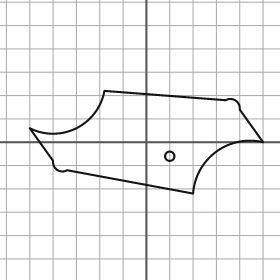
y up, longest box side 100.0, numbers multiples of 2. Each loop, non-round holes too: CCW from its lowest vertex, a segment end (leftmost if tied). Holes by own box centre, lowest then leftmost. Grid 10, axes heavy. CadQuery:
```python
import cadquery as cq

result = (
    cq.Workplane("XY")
    .moveTo(20.0, -22.0)
    .threePointArc((30.0, -4.0), (50.0, 0.0))
    .lineTo(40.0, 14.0)
    .threePointArc((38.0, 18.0), (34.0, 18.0))
    .lineTo(-18.0, 22.0)
    .threePointArc((-30.0, 6.0), (-50.0, 6.0))
    .lineTo(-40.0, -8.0)
    .threePointArc((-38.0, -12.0), (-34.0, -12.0))
    .close()
    .moveTo(10.0, -6.0)
    .circle(2.0)
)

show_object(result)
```